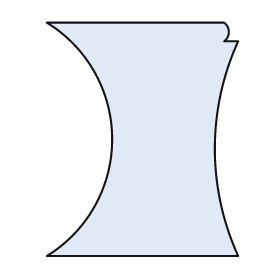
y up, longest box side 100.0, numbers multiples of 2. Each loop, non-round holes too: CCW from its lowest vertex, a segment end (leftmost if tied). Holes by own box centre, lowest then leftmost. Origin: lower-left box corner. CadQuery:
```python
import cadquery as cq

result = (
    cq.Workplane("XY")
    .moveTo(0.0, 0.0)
    .lineTo(82.0, 0.0)
    .threePointArc((72.0, 46.0), (82.0, 92.0))
    .lineTo(76.0, 92.0)
    .threePointArc((78.0, 96.0), (76.0, 100.0))
    .lineTo(0.0, 100.0)
    .threePointArc((28.0, 50.0), (0.0, 0.0))
    .close()
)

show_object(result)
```